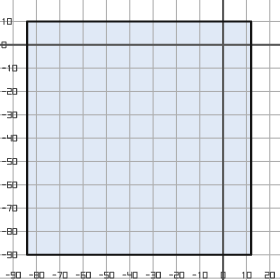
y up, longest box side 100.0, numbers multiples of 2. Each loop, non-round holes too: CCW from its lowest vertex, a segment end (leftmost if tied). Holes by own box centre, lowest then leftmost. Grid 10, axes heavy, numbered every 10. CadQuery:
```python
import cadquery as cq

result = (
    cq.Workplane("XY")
    .moveTo(-84.0, -90.0)
    .lineTo(12.0, -90.0)
    .lineTo(12.0, 10.0)
    .lineTo(-84.0, 10.0)
    .close()
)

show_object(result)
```